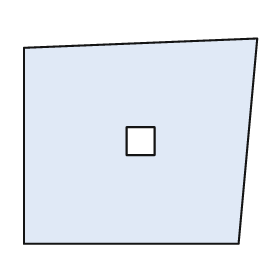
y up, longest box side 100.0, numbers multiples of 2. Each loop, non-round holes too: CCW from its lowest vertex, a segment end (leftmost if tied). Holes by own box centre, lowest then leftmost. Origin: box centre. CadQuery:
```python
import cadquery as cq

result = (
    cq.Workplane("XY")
    .moveTo(-50.0, -44.0)
    .lineTo(42.0, -44.0)
    .lineTo(50.0, 44.0)
    .lineTo(-50.0, 40.0)
    .close()
    .moveTo(-6.0, -6.0)
    .lineTo(6.0, -6.0)
    .lineTo(6.0, 6.0)
    .lineTo(-6.0, 6.0)
    .close()
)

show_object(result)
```